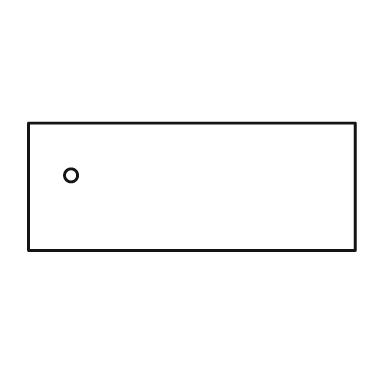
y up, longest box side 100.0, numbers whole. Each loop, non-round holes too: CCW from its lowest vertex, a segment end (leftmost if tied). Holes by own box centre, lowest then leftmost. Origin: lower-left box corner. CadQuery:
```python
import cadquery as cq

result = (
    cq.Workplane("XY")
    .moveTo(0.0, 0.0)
    .lineTo(100.0, 0.0)
    .lineTo(100.0, 39.0)
    .lineTo(0.0, 39.0)
    .close()
    .moveTo(13.0, 23.0)
    .circle(2.0)
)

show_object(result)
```